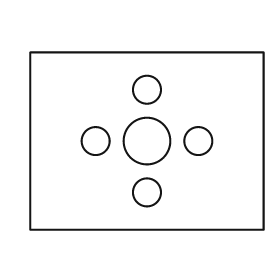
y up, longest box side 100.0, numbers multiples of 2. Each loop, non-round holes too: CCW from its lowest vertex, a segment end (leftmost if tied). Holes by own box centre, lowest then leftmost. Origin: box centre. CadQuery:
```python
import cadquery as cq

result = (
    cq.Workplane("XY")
    .moveTo(-50.0, -38.0)
    .lineTo(50.0, -38.0)
    .lineTo(50.0, 38.0)
    .lineTo(-50.0, 38.0)
    .close()
    .moveTo(0.0, -22.0)
    .circle(6.0)
    .moveTo(-22.0, 0.0)
    .circle(6.0)
    .moveTo(0.0, 0.0)
    .circle(10.0)
    .moveTo(22.0, 0.0)
    .circle(6.0)
    .moveTo(0.0, 22.0)
    .circle(6.0)
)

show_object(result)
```